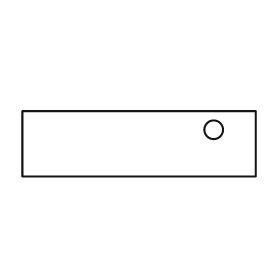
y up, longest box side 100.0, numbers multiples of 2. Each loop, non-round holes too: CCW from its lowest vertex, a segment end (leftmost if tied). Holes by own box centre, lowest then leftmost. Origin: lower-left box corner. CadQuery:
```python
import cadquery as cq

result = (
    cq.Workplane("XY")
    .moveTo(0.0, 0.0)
    .lineTo(100.0, 0.0)
    .lineTo(100.0, 28.0)
    .lineTo(0.0, 28.0)
    .close()
    .moveTo(82.0, 20.0)
    .circle(4.0)
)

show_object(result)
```